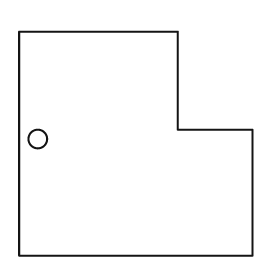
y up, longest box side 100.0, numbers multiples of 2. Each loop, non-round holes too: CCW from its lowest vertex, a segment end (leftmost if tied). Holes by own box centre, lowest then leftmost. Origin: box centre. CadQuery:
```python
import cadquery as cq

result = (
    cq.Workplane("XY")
    .moveTo(-50.0, -48.0)
    .lineTo(50.0, -48.0)
    .lineTo(50.0, 6.0)
    .lineTo(18.0, 6.0)
    .lineTo(18.0, 48.0)
    .lineTo(-50.0, 48.0)
    .close()
    .moveTo(-42.0, 2.0)
    .circle(4.0)
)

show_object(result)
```